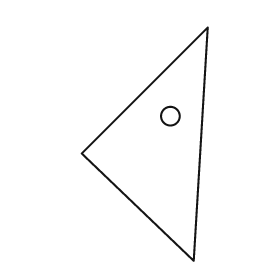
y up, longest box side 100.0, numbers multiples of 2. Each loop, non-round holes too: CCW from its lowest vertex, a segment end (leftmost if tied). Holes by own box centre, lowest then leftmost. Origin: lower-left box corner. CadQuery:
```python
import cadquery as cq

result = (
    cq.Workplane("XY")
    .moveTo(48.0, 0.0)
    .lineTo(54.0, 100.0)
    .lineTo(0.0, 46.0)
    .close()
    .moveTo(38.0, 62.0)
    .circle(4.0)
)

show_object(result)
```